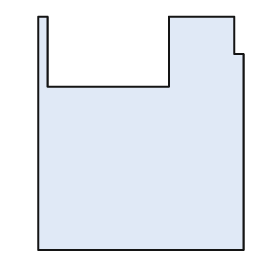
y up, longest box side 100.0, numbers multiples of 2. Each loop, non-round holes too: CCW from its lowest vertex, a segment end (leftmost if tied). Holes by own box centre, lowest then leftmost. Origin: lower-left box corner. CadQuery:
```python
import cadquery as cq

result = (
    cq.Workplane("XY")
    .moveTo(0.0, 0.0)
    .lineTo(88.0, 0.0)
    .lineTo(88.0, 84.0)
    .lineTo(84.0, 84.0)
    .lineTo(84.0, 100.0)
    .lineTo(56.0, 100.0)
    .lineTo(56.0, 70.0)
    .lineTo(4.0, 70.0)
    .lineTo(4.0, 100.0)
    .lineTo(0.0, 100.0)
    .close()
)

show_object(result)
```